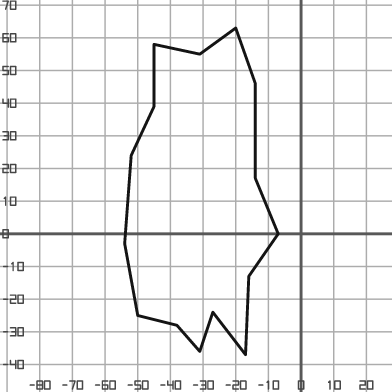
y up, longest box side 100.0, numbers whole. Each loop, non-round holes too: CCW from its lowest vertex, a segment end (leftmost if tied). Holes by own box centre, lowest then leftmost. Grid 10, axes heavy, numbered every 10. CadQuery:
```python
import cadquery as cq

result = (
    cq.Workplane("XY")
    .moveTo(-17.0, -37.0)
    .lineTo(-16.0, -13.0)
    .lineTo(-7.0, 0.0)
    .lineTo(-14.0, 17.0)
    .lineTo(-14.0, 46.0)
    .lineTo(-20.0, 63.0)
    .lineTo(-31.0, 55.0)
    .lineTo(-45.0, 58.0)
    .lineTo(-45.0, 39.0)
    .lineTo(-52.0, 24.0)
    .lineTo(-54.0, -3.0)
    .lineTo(-50.0, -25.0)
    .lineTo(-38.0, -28.0)
    .lineTo(-31.0, -36.0)
    .lineTo(-27.0, -24.0)
    .close()
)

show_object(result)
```